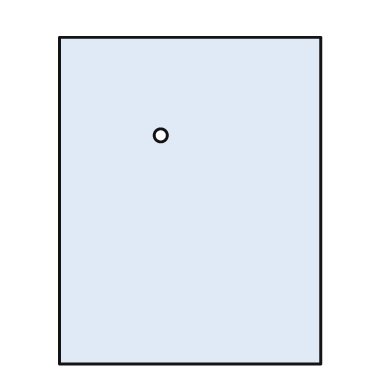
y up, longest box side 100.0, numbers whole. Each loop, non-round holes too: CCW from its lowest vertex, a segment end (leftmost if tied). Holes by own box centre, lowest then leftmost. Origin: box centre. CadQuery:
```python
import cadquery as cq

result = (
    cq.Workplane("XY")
    .moveTo(-40.0, -50.0)
    .lineTo(40.0, -50.0)
    .lineTo(40.0, 50.0)
    .lineTo(-40.0, 50.0)
    .close()
    .moveTo(-9.0, 20.0)
    .circle(2.0)
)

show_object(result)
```